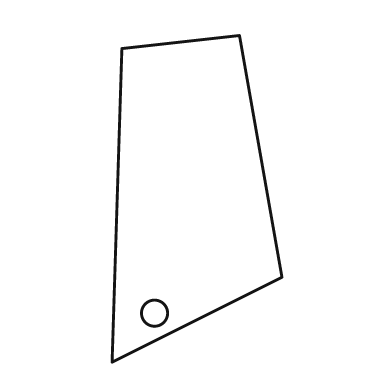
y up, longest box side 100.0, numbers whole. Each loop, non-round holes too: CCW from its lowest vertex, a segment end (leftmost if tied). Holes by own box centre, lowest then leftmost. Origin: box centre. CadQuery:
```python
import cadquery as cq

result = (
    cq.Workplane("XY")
    .moveTo(-26.0, -50.0)
    .lineTo(26.0, -24.0)
    .lineTo(13.0, 50.0)
    .lineTo(-23.0, 46.0)
    .close()
    .moveTo(-13.0, -35.0)
    .circle(4.0)
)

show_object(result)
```